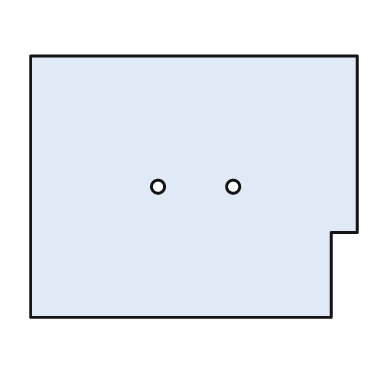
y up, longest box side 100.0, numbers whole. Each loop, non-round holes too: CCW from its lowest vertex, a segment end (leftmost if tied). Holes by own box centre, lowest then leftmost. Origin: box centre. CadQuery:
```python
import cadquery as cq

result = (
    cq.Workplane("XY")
    .moveTo(-50.0, -40.0)
    .lineTo(42.0, -40.0)
    .lineTo(42.0, -14.0)
    .lineTo(50.0, -14.0)
    .lineTo(50.0, 40.0)
    .lineTo(-50.0, 40.0)
    .close()
    .moveTo(-11.0, 0.0)
    .circle(2.0)
    .moveTo(12.0, 0.0)
    .circle(2.0)
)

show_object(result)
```